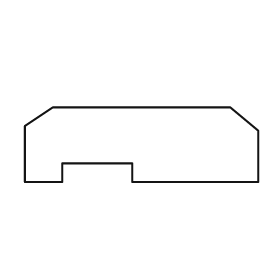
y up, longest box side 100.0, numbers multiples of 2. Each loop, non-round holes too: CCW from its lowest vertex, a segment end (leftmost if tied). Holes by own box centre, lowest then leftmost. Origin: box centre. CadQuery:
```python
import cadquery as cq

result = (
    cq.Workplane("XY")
    .moveTo(-50.0, -16.0)
    .lineTo(-34.0, -16.0)
    .lineTo(-34.0, -8.0)
    .lineTo(-4.0, -8.0)
    .lineTo(-4.0, -16.0)
    .lineTo(50.0, -16.0)
    .lineTo(50.0, 6.0)
    .lineTo(38.0, 16.0)
    .lineTo(-38.0, 16.0)
    .lineTo(-50.0, 8.0)
    .close()
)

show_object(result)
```